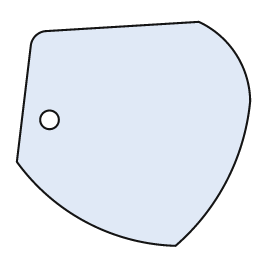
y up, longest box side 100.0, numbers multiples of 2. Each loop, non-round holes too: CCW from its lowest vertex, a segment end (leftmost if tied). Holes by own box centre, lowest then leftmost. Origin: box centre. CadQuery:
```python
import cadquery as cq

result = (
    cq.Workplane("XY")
    .moveTo(18.0, -48.0)
    .threePointArc((40.0, -20.0), (50.0, 14.0))
    .threePointArc((44.0, 34.0), (28.0, 48.0))
    .lineTo(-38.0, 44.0)
    .threePointArc((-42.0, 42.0), (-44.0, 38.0))
    .lineTo(-50.0, -12.0)
    .threePointArc((-20.0, -38.0), (18.0, -48.0))
    .close()
    .moveTo(-36.0, 6.0)
    .circle(4.0)
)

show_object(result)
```